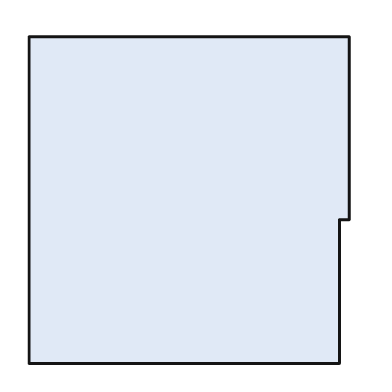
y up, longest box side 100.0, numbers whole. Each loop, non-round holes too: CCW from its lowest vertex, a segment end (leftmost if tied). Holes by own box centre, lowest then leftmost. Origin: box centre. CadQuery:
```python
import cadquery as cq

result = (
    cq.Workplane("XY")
    .moveTo(-49.0, -50.0)
    .lineTo(46.0, -50.0)
    .lineTo(46.0, -6.0)
    .lineTo(49.0, -6.0)
    .lineTo(49.0, 50.0)
    .lineTo(-49.0, 50.0)
    .close()
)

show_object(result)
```